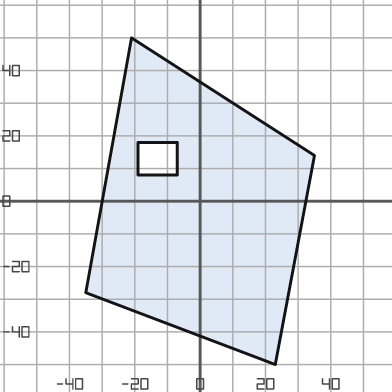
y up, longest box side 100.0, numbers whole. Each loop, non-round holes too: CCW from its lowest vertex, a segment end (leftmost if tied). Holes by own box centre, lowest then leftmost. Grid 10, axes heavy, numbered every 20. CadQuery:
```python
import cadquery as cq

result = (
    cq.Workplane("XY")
    .moveTo(23.0, -50.0)
    .lineTo(35.0, 14.0)
    .lineTo(-21.0, 50.0)
    .lineTo(-35.0, -28.0)
    .close()
    .moveTo(-19.0, 8.0)
    .lineTo(-7.0, 8.0)
    .lineTo(-7.0, 18.0)
    .lineTo(-19.0, 18.0)
    .close()
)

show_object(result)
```